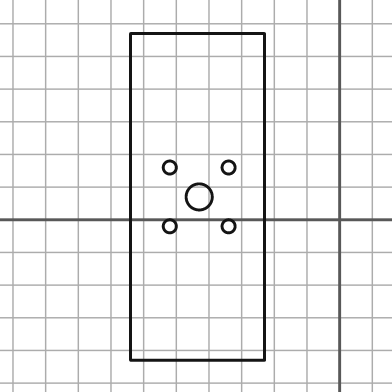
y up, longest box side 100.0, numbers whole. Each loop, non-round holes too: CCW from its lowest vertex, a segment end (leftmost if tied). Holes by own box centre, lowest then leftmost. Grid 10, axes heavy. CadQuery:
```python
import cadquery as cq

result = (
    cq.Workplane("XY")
    .moveTo(-64.0, -43.0)
    .lineTo(-23.0, -43.0)
    .lineTo(-23.0, 57.0)
    .lineTo(-64.0, 57.0)
    .close()
    .moveTo(-52.0, -2.0)
    .circle(2.0)
    .moveTo(-34.0, -2.0)
    .circle(2.0)
    .moveTo(-43.0, 7.0)
    .circle(4.0)
    .moveTo(-52.0, 16.0)
    .circle(2.0)
    .moveTo(-34.0, 16.0)
    .circle(2.0)
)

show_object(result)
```